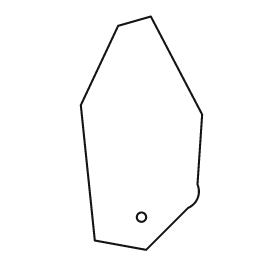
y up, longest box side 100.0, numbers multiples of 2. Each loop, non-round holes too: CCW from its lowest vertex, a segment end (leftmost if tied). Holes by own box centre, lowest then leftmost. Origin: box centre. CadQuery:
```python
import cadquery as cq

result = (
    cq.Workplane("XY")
    .moveTo(2.0, -50.0)
    .lineTo(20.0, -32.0)
    .threePointArc((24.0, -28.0), (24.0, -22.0))
    .lineTo(26.0, 8.0)
    .lineTo(4.0, 50.0)
    .lineTo(-10.0, 46.0)
    .lineTo(-26.0, 12.0)
    .lineTo(-20.0, -46.0)
    .close()
    .moveTo(0.0, -36.0)
    .circle(2.0)
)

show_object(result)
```